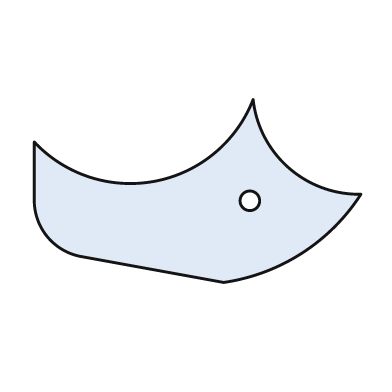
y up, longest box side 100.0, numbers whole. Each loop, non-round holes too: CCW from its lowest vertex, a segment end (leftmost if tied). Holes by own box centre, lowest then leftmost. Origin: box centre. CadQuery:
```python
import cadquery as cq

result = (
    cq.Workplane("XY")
    .moveTo(8.0, -28.0)
    .threePointArc((32.0, -19.0), (50.0, -1.0))
    .threePointArc((28.0, 7.0), (17.0, 28.0))
    .threePointArc((-13.0, 3.0), (-50.0, 15.0))
    .lineTo(-50.0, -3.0)
    .threePointArc((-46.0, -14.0), (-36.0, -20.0))
    .close()
    .moveTo(16.0, -3.0)
    .circle(3.0)
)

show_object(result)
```